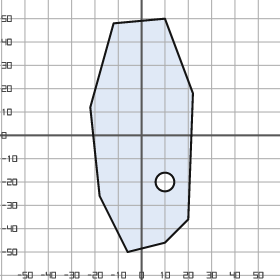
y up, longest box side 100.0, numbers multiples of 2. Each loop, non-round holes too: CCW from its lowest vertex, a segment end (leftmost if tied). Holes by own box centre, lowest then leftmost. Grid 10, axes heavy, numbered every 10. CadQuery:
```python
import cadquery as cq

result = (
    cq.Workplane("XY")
    .moveTo(-6.0, -50.0)
    .lineTo(10.0, -46.0)
    .lineTo(20.0, -36.0)
    .lineTo(22.0, 18.0)
    .lineTo(10.0, 50.0)
    .lineTo(-12.0, 48.0)
    .lineTo(-22.0, 12.0)
    .lineTo(-18.0, -26.0)
    .close()
    .moveTo(10.0, -20.0)
    .circle(4.0)
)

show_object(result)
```